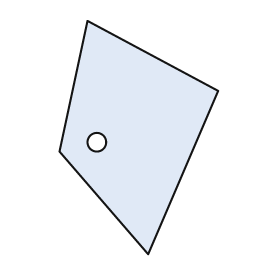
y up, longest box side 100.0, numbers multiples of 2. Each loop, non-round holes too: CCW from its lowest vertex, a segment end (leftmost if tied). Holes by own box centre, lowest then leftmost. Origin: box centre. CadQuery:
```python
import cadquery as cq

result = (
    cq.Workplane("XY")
    .moveTo(4.0, -50.0)
    .lineTo(34.0, 20.0)
    .lineTo(-22.0, 50.0)
    .lineTo(-34.0, -6.0)
    .close()
    .moveTo(-18.0, -2.0)
    .circle(4.0)
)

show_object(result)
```